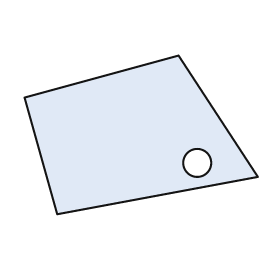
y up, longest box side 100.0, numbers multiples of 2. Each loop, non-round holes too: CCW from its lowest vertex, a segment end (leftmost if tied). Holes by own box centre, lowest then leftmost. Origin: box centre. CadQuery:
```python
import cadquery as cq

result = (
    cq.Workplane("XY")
    .moveTo(-36.0, -34.0)
    .lineTo(50.0, -18.0)
    .lineTo(16.0, 34.0)
    .lineTo(-50.0, 16.0)
    .close()
    .moveTo(24.0, -12.0)
    .circle(6.0)
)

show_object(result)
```